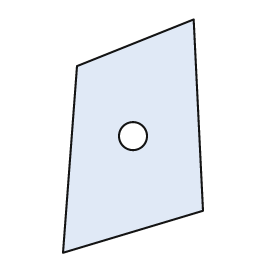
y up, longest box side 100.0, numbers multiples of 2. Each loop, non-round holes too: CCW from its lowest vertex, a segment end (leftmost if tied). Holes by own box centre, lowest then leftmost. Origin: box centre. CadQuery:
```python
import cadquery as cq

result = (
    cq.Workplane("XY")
    .moveTo(-30.0, -50.0)
    .lineTo(30.0, -32.0)
    .lineTo(26.0, 50.0)
    .lineTo(-24.0, 30.0)
    .close()
    .moveTo(0.0, 0.0)
    .circle(6.0)
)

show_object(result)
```